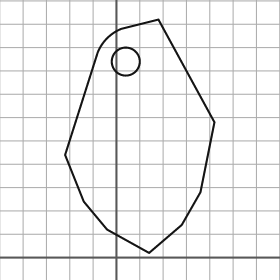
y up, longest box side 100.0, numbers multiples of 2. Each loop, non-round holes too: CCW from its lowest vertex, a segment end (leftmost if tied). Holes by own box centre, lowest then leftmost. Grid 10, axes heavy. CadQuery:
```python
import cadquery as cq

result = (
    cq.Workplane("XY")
    .moveTo(14.0, 2.0)
    .lineTo(28.0, 14.0)
    .lineTo(36.0, 28.0)
    .lineTo(42.0, 58.0)
    .lineTo(18.0, 102.0)
    .lineTo(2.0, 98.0)
    .threePointArc((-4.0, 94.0), (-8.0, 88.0))
    .lineTo(-22.0, 44.0)
    .lineTo(-14.0, 24.0)
    .lineTo(-4.0, 12.0)
    .close()
    .moveTo(4.0, 84.0)
    .circle(6.0)
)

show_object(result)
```